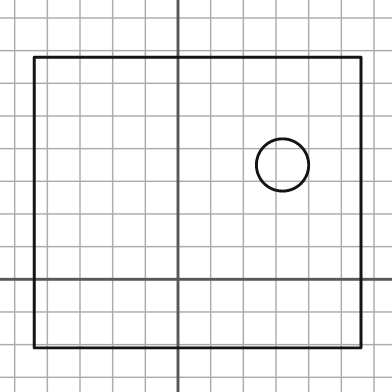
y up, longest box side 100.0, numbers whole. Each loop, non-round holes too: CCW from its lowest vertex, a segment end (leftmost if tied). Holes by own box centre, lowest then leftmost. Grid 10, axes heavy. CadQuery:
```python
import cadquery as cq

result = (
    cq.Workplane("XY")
    .moveTo(-44.0, -21.0)
    .lineTo(56.0, -21.0)
    .lineTo(56.0, 68.0)
    .lineTo(-44.0, 68.0)
    .close()
    .moveTo(32.0, 35.0)
    .circle(8.0)
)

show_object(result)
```